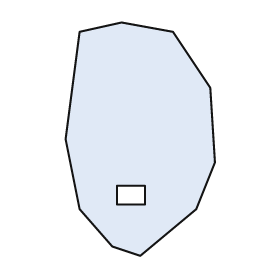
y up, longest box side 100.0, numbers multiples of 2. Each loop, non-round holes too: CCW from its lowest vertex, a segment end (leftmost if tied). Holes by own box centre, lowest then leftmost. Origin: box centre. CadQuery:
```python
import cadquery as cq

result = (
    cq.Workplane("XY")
    .moveTo(0.0, -50.0)
    .lineTo(24.0, -30.0)
    .lineTo(32.0, -10.0)
    .lineTo(30.0, 22.0)
    .lineTo(14.0, 46.0)
    .lineTo(-8.0, 50.0)
    .lineTo(-26.0, 46.0)
    .lineTo(-32.0, 0.0)
    .lineTo(-26.0, -30.0)
    .lineTo(-12.0, -46.0)
    .close()
    .moveTo(-10.0, -28.0)
    .lineTo(2.0, -28.0)
    .lineTo(2.0, -20.0)
    .lineTo(-10.0, -20.0)
    .close()
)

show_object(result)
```